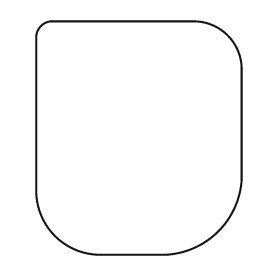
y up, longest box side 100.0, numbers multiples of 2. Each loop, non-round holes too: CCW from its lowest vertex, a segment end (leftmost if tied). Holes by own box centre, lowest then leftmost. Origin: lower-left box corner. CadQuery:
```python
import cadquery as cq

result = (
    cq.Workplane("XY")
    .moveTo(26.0, 0.0)
    .lineTo(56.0, 0.0)
    .threePointArc((78.0, 10.0), (88.0, 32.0))
    .lineTo(88.0, 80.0)
    .threePointArc((82.0, 94.0), (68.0, 100.0))
    .lineTo(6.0, 100.0)
    .threePointArc((2.0, 98.0), (0.0, 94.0))
    .lineTo(0.0, 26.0)
    .threePointArc((8.0, 8.0), (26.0, 0.0))
    .close()
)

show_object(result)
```